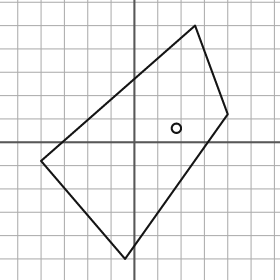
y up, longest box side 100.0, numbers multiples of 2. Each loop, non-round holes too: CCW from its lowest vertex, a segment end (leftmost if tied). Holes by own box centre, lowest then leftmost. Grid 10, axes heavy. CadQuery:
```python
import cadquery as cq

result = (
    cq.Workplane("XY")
    .moveTo(-4.0, -50.0)
    .lineTo(40.0, 12.0)
    .lineTo(26.0, 50.0)
    .lineTo(-40.0, -8.0)
    .close()
    .moveTo(18.0, 6.0)
    .circle(2.0)
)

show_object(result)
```